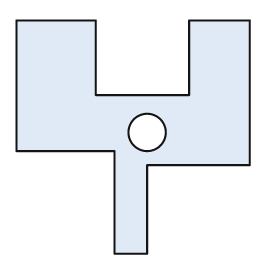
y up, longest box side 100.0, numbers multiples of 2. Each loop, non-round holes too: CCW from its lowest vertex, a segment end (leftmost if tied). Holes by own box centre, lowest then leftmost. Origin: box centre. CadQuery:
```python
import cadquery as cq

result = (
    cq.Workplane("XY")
    .moveTo(-8.0, -50.0)
    .lineTo(6.0, -50.0)
    .lineTo(6.0, -12.0)
    .lineTo(50.0, -12.0)
    .lineTo(50.0, 50.0)
    .lineTo(24.0, 50.0)
    .lineTo(24.0, 18.0)
    .lineTo(-16.0, 18.0)
    .lineTo(-16.0, 50.0)
    .lineTo(-50.0, 50.0)
    .lineTo(-50.0, -6.0)
    .lineTo(-8.0, -6.0)
    .close()
    .moveTo(6.0, 2.0)
    .circle(8.0)
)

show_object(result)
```